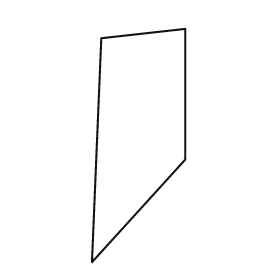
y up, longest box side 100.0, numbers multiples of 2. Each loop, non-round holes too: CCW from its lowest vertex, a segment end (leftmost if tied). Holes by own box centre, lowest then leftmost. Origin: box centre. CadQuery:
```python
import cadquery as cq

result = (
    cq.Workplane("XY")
    .moveTo(-20.0, -50.0)
    .lineTo(20.0, -6.0)
    .lineTo(20.0, 50.0)
    .lineTo(-16.0, 46.0)
    .close()
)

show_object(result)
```